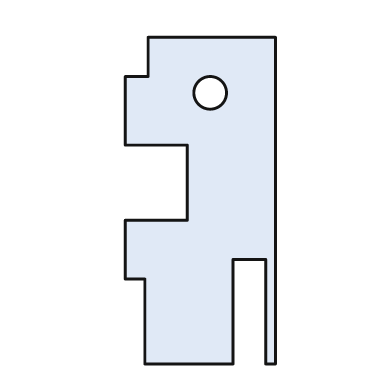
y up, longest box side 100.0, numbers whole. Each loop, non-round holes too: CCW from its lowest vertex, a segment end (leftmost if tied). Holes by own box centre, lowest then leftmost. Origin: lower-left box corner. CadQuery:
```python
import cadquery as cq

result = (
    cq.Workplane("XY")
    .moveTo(6.0, 0.0)
    .lineTo(33.0, 0.0)
    .lineTo(33.0, 32.0)
    .lineTo(43.0, 32.0)
    .lineTo(43.0, 0.0)
    .lineTo(46.0, 0.0)
    .lineTo(46.0, 100.0)
    .lineTo(7.0, 100.0)
    .lineTo(7.0, 88.0)
    .lineTo(0.0, 88.0)
    .lineTo(0.0, 67.0)
    .lineTo(19.0, 67.0)
    .lineTo(19.0, 44.0)
    .lineTo(0.0, 44.0)
    .lineTo(0.0, 26.0)
    .lineTo(6.0, 26.0)
    .close()
    .moveTo(26.0, 83.0)
    .circle(5.0)
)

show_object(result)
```